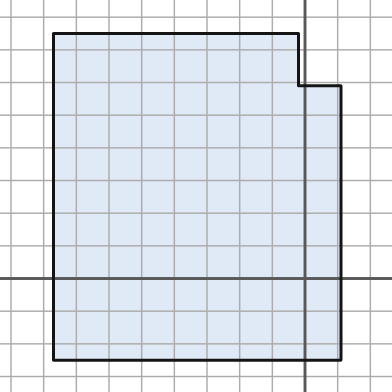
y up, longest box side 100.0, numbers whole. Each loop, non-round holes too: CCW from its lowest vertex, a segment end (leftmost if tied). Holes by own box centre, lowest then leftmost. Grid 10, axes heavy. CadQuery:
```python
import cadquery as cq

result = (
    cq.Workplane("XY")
    .moveTo(-77.0, -25.0)
    .lineTo(11.0, -25.0)
    .lineTo(11.0, 59.0)
    .lineTo(-2.0, 59.0)
    .lineTo(-2.0, 75.0)
    .lineTo(-77.0, 75.0)
    .close()
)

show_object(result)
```